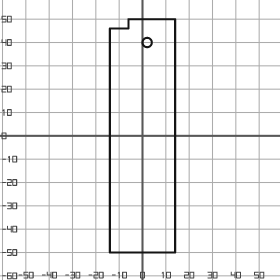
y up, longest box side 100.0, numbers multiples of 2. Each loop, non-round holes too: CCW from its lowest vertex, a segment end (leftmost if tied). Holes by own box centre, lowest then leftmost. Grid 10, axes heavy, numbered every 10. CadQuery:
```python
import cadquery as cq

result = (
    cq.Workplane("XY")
    .moveTo(-14.0, -50.0)
    .lineTo(14.0, -50.0)
    .lineTo(14.0, 50.0)
    .lineTo(-6.0, 50.0)
    .lineTo(-6.0, 46.0)
    .lineTo(-14.0, 46.0)
    .close()
    .moveTo(2.0, 40.0)
    .circle(2.0)
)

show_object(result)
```